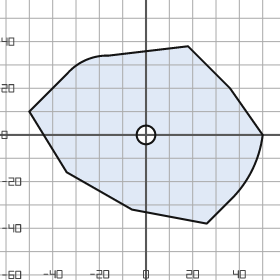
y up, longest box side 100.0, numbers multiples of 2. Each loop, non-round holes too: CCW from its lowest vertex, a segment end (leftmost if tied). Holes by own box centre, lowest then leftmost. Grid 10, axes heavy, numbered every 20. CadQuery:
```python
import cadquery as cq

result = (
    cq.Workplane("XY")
    .moveTo(26.0, -38.0)
    .lineTo(38.0, -26.0)
    .threePointArc((46.0, -14.0), (50.0, 0.0))
    .lineTo(36.0, 20.0)
    .lineTo(18.0, 38.0)
    .lineTo(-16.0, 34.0)
    .threePointArc((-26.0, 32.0), (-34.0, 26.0))
    .lineTo(-50.0, 10.0)
    .lineTo(-34.0, -16.0)
    .lineTo(-6.0, -32.0)
    .close()
    .moveTo(0.0, 0.0)
    .circle(4.0)
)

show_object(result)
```